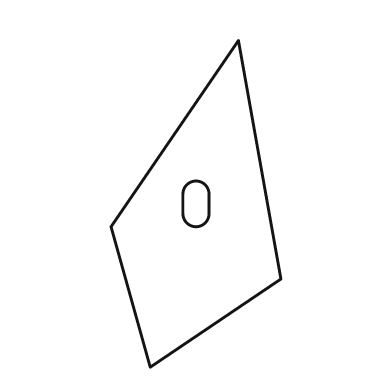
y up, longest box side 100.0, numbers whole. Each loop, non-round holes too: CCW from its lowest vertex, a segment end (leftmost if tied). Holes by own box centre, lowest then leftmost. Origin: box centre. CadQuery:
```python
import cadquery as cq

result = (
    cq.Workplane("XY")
    .moveTo(-14.0, -50.0)
    .lineTo(26.0, -23.0)
    .lineTo(13.0, 50.0)
    .lineTo(-26.0, -7.0)
    .close()
    .moveTo(-4.0, -3.0)
    .threePointArc((0.0, -7.0), (4.0, -3.0))
    .lineTo(4.0, 3.0)
    .threePointArc((0.0, 7.0), (-4.0, 3.0))
    .close()
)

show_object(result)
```